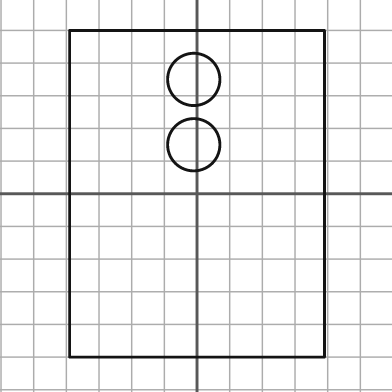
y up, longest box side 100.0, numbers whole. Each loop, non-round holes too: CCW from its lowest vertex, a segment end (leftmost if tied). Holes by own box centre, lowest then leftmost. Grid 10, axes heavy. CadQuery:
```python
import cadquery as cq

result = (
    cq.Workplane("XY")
    .moveTo(-39.0, -50.0)
    .lineTo(39.0, -50.0)
    .lineTo(39.0, 50.0)
    .lineTo(-39.0, 50.0)
    .close()
    .moveTo(-1.0, 15.0)
    .circle(8.0)
    .moveTo(-1.0, 35.0)
    .circle(8.0)
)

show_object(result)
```